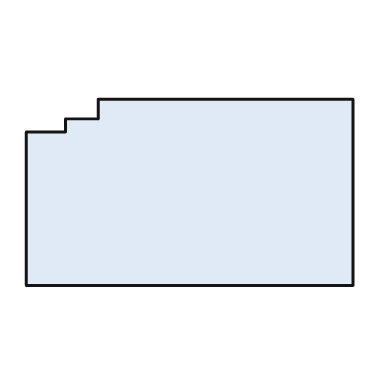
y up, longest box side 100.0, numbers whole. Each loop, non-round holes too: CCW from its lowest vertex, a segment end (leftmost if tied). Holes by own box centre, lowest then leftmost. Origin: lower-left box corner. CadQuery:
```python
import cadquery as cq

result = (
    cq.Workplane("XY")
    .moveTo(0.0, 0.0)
    .lineTo(100.0, 0.0)
    .lineTo(100.0, 57.0)
    .lineTo(22.0, 57.0)
    .lineTo(22.0, 51.0)
    .lineTo(12.0, 51.0)
    .lineTo(12.0, 47.0)
    .lineTo(0.0, 47.0)
    .close()
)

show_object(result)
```